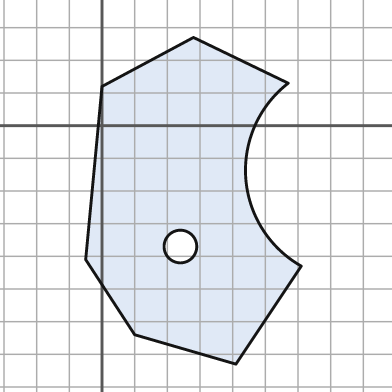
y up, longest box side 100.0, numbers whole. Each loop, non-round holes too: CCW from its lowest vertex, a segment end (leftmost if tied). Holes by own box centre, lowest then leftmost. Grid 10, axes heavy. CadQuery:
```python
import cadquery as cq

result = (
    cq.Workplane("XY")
    .moveTo(41.0, -73.0)
    .lineTo(61.0, -43.0)
    .threePointArc((44.0, -16.0), (57.0, 13.0))
    .lineTo(28.0, 27.0)
    .lineTo(0.0, 12.0)
    .lineTo(-5.0, -41.0)
    .lineTo(10.0, -64.0)
    .close()
    .moveTo(24.0, -37.0)
    .circle(5.0)
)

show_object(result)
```